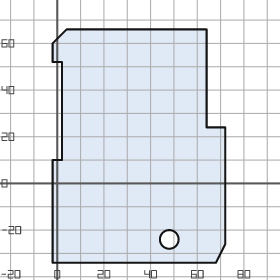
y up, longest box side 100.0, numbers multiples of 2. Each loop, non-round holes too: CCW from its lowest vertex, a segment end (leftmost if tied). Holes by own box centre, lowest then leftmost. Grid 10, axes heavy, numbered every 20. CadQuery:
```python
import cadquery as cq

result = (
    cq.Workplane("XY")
    .moveTo(-2.0, -34.0)
    .lineTo(68.0, -34.0)
    .lineTo(72.0, -26.0)
    .lineTo(72.0, 24.0)
    .lineTo(64.0, 24.0)
    .lineTo(64.0, 66.0)
    .lineTo(4.0, 66.0)
    .lineTo(-2.0, 60.0)
    .lineTo(-2.0, 52.0)
    .lineTo(2.0, 52.0)
    .lineTo(2.0, 10.0)
    .lineTo(-2.0, 10.0)
    .close()
    .moveTo(48.0, -24.0)
    .circle(4.0)
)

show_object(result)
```